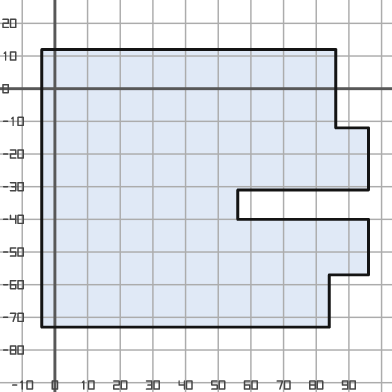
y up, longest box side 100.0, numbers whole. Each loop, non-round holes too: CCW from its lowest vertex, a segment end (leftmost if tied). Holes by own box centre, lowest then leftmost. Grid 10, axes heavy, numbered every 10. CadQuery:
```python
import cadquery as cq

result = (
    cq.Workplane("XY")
    .moveTo(-4.0, -73.0)
    .lineTo(84.0, -73.0)
    .lineTo(84.0, -57.0)
    .lineTo(96.0, -57.0)
    .lineTo(96.0, -40.0)
    .lineTo(56.0, -40.0)
    .lineTo(56.0, -31.0)
    .lineTo(96.0, -31.0)
    .lineTo(96.0, -12.0)
    .lineTo(86.0, -12.0)
    .lineTo(86.0, 12.0)
    .lineTo(-4.0, 12.0)
    .close()
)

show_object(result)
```